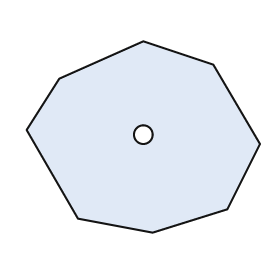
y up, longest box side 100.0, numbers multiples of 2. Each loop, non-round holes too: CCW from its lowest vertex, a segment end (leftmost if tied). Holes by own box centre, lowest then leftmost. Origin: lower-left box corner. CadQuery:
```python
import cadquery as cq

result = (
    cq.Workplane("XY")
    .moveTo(54.0, 0.0)
    .lineTo(86.0, 10.0)
    .lineTo(100.0, 38.0)
    .lineTo(80.0, 72.0)
    .lineTo(50.0, 82.0)
    .lineTo(14.0, 66.0)
    .lineTo(0.0, 44.0)
    .lineTo(22.0, 6.0)
    .close()
    .moveTo(50.0, 42.0)
    .circle(4.0)
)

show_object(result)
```